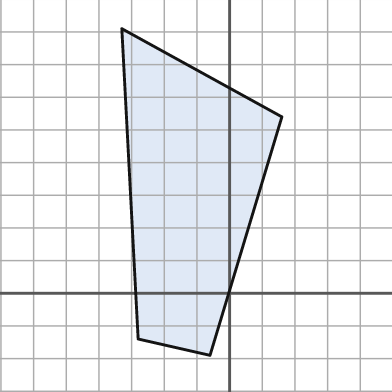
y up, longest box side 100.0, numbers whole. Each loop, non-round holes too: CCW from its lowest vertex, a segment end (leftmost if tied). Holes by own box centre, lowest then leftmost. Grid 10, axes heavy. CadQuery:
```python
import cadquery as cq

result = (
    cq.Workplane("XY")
    .moveTo(-6.0, -19.0)
    .lineTo(16.0, 54.0)
    .lineTo(-33.0, 81.0)
    .lineTo(-28.0, -14.0)
    .close()
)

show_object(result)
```